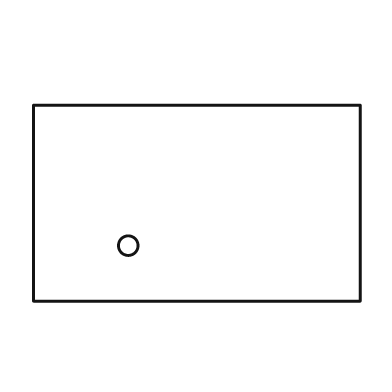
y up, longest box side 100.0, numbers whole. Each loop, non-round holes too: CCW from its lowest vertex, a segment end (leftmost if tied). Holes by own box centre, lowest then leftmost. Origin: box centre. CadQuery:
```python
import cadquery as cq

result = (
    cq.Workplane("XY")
    .moveTo(-50.0, -30.0)
    .lineTo(50.0, -30.0)
    .lineTo(50.0, 30.0)
    .lineTo(-50.0, 30.0)
    .close()
    .moveTo(-21.0, -13.0)
    .circle(3.0)
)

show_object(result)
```